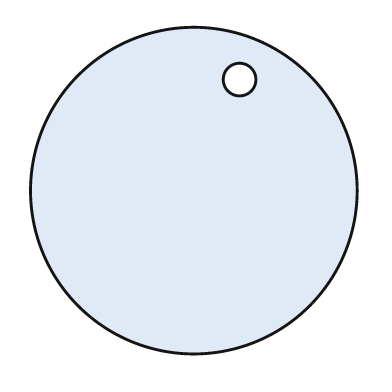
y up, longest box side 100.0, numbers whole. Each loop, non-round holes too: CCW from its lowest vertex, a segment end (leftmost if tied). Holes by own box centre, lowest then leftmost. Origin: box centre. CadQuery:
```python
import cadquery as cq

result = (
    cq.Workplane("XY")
    .moveTo(0.0, 0.0)
    .circle(50.0)
    .moveTo(14.0, 34.0)
    .circle(5.0)
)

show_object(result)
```